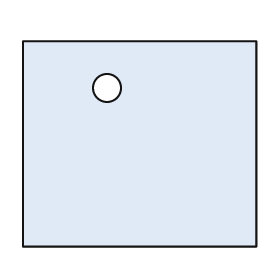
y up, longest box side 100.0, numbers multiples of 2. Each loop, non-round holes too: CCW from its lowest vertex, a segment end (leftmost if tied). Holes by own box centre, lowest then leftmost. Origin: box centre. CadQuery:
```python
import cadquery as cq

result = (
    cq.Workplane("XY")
    .moveTo(-50.0, -44.0)
    .lineTo(50.0, -44.0)
    .lineTo(50.0, 44.0)
    .lineTo(-50.0, 44.0)
    .close()
    .moveTo(-14.0, 24.0)
    .circle(6.0)
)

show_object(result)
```